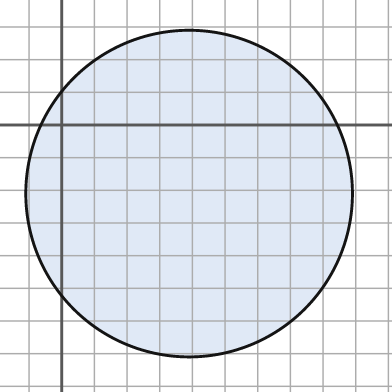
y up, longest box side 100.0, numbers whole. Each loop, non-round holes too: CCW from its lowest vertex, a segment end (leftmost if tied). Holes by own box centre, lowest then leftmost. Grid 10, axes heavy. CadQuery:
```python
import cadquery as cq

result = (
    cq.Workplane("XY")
    .moveTo(39.0, -21.0)
    .circle(50.0)
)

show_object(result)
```